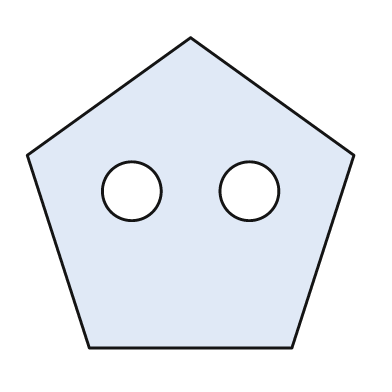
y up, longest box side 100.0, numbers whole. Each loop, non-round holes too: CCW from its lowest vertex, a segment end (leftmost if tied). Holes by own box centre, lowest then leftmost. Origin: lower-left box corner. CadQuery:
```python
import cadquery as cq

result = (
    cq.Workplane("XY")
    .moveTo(19.0, 0.0)
    .lineTo(81.0, 0.0)
    .lineTo(100.0, 59.0)
    .lineTo(50.0, 95.0)
    .lineTo(0.0, 59.0)
    .close()
    .moveTo(32.0, 48.0)
    .circle(9.0)
    .moveTo(68.0, 48.0)
    .circle(9.0)
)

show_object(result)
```